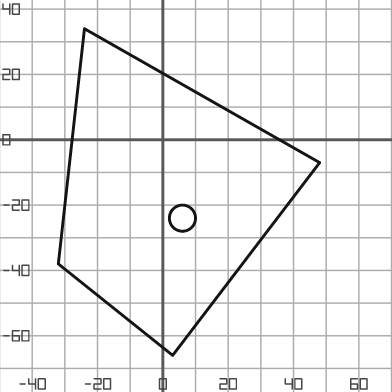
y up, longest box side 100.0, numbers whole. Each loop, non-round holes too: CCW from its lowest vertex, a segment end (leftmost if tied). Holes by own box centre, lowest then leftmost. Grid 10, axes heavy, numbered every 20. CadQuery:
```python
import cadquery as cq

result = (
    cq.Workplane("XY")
    .moveTo(3.0, -66.0)
    .lineTo(48.0, -7.0)
    .lineTo(-24.0, 34.0)
    .lineTo(-32.0, -38.0)
    .close()
    .moveTo(6.0, -24.0)
    .circle(4.0)
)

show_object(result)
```